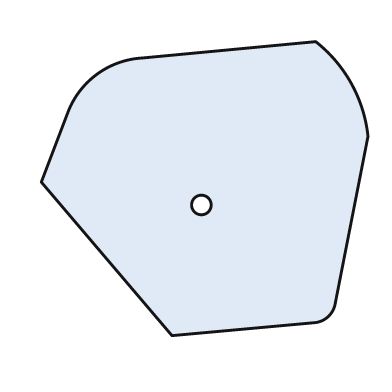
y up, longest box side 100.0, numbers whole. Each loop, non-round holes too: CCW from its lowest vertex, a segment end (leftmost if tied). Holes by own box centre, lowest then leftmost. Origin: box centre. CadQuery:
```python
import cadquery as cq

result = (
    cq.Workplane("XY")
    .moveTo(-10.0, -45.0)
    .lineTo(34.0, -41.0)
    .threePointArc((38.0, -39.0), (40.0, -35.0))
    .lineTo(50.0, 16.0)
    .threePointArc((45.0, 32.0), (34.0, 45.0))
    .lineTo(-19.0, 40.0)
    .threePointArc((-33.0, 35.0), (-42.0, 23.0))
    .lineTo(-50.0, 2.0)
    .close()
    .moveTo(-1.0, -5.0)
    .circle(3.0)
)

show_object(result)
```